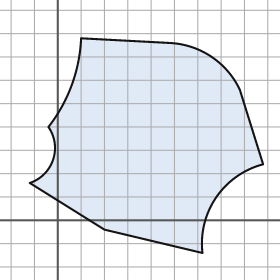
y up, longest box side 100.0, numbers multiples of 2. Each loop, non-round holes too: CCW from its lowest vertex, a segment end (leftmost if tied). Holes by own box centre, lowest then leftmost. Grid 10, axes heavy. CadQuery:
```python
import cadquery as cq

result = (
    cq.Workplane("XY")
    .moveTo(62.0, -14.0)
    .threePointArc((68.0, 10.0), (88.0, 24.0))
    .lineTo(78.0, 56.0)
    .threePointArc((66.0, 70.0), (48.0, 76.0))
    .lineTo(10.0, 78.0)
    .threePointArc((6.0, 58.0), (-4.0, 40.0))
    .threePointArc((-2.0, 26.0), (-12.0, 16.0))
    .lineTo(20.0, -4.0)
    .close()
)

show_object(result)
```